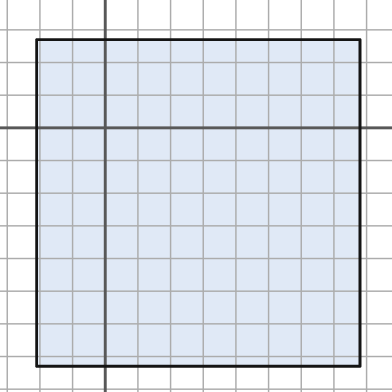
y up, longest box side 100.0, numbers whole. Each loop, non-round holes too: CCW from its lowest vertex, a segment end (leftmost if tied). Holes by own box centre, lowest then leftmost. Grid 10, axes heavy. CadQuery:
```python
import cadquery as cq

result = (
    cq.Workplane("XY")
    .moveTo(-21.0, -73.0)
    .lineTo(78.0, -73.0)
    .lineTo(78.0, 27.0)
    .lineTo(-21.0, 27.0)
    .close()
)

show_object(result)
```